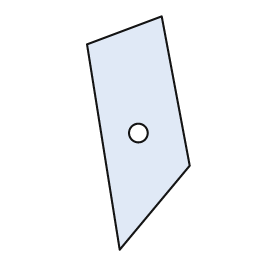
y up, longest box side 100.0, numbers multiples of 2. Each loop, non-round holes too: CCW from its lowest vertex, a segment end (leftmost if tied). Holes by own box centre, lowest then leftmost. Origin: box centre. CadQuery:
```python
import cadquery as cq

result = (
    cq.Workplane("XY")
    .moveTo(-8.0, -50.0)
    .lineTo(22.0, -14.0)
    .lineTo(10.0, 50.0)
    .lineTo(-22.0, 38.0)
    .close()
    .moveTo(0.0, 0.0)
    .circle(4.0)
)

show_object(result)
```